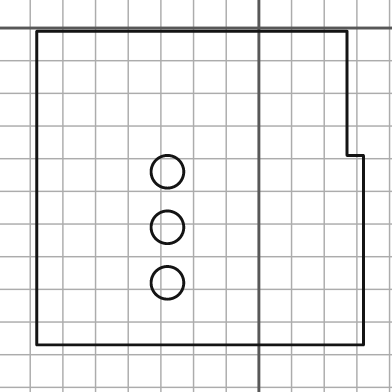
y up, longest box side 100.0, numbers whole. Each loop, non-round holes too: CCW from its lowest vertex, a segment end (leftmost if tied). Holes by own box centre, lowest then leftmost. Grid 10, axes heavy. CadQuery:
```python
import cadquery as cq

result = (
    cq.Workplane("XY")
    .moveTo(-68.0, -97.0)
    .lineTo(32.0, -97.0)
    .lineTo(32.0, -39.0)
    .lineTo(27.0, -39.0)
    .lineTo(27.0, -1.0)
    .lineTo(-68.0, -1.0)
    .close()
    .moveTo(-28.0, -78.0)
    .circle(5.0)
    .moveTo(-28.0, -61.0)
    .circle(5.0)
    .moveTo(-28.0, -44.0)
    .circle(5.0)
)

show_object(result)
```